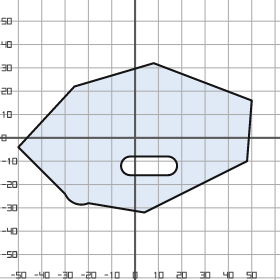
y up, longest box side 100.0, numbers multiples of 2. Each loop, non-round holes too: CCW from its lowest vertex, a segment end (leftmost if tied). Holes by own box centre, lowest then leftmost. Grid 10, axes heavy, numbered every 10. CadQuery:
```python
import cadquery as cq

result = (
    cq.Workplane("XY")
    .moveTo(4.0, -32.0)
    .lineTo(48.0, -10.0)
    .lineTo(50.0, 16.0)
    .lineTo(8.0, 32.0)
    .lineTo(-26.0, 22.0)
    .lineTo(-50.0, -4.0)
    .lineTo(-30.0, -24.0)
    .threePointArc((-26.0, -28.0), (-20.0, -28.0))
    .close()
    .moveTo(-2.0, -16.0)
    .lineTo(14.0, -16.0)
    .threePointArc((18.0, -12.0), (14.0, -8.0))
    .lineTo(-2.0, -8.0)
    .threePointArc((-6.0, -12.0), (-2.0, -16.0))
    .close()
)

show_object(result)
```